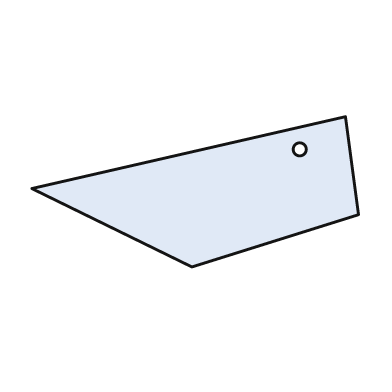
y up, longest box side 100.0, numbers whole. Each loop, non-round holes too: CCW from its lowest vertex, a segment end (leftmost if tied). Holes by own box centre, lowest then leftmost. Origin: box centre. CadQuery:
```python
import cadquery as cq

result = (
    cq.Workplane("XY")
    .moveTo(-1.0, -23.0)
    .lineTo(50.0, -7.0)
    .lineTo(46.0, 23.0)
    .lineTo(-50.0, 1.0)
    .close()
    .moveTo(32.0, 13.0)
    .circle(2.0)
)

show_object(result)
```